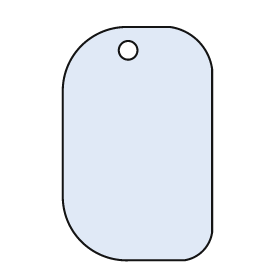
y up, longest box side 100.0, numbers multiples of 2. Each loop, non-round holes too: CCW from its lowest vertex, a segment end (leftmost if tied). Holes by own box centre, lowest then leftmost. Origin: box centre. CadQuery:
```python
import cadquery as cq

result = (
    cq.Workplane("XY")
    .moveTo(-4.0, -50.0)
    .lineTo(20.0, -50.0)
    .threePointArc((28.0, -46.0), (32.0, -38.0))
    .lineTo(32.0, 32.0)
    .threePointArc((26.0, 44.0), (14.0, 50.0))
    .lineTo(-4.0, 50.0)
    .threePointArc((-24.0, 42.0), (-32.0, 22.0))
    .lineTo(-32.0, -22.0)
    .threePointArc((-24.0, -42.0), (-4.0, -50.0))
    .close()
    .moveTo(-4.0, 40.0)
    .circle(4.0)
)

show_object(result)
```